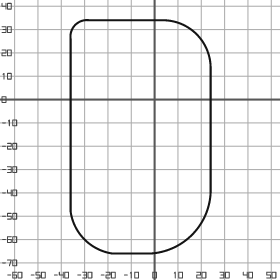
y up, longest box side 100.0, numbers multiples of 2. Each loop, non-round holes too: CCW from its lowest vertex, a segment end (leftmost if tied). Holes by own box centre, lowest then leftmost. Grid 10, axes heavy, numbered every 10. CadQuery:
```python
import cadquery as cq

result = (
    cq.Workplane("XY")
    .moveTo(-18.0, -66.0)
    .lineTo(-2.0, -66.0)
    .threePointArc((16.0, -58.0), (24.0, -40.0))
    .lineTo(24.0, 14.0)
    .threePointArc((18.0, 28.0), (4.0, 34.0))
    .lineTo(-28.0, 34.0)
    .threePointArc((-34.0, 32.0), (-36.0, 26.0))
    .lineTo(-36.0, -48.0)
    .threePointArc((-30.0, -60.0), (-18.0, -66.0))
    .close()
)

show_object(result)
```